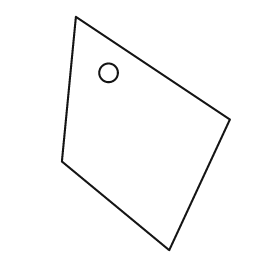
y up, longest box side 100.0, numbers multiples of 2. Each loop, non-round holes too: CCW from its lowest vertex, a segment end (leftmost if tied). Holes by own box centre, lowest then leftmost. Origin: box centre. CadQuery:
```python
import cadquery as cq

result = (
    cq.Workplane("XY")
    .moveTo(10.0, -50.0)
    .lineTo(36.0, 6.0)
    .lineTo(-30.0, 50.0)
    .lineTo(-36.0, -12.0)
    .close()
    .moveTo(-16.0, 26.0)
    .circle(4.0)
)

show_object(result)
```